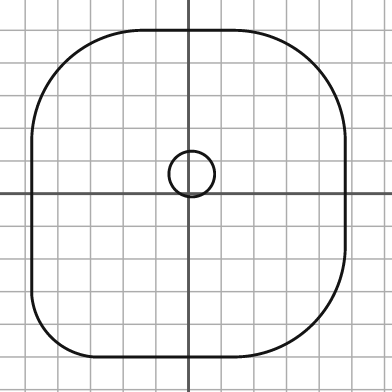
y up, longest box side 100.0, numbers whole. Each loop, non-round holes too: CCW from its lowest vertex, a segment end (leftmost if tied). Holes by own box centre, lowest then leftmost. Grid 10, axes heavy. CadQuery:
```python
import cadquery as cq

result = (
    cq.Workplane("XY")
    .moveTo(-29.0, -50.0)
    .lineTo(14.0, -50.0)
    .threePointArc((38.0, -40.0), (48.0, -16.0))
    .lineTo(48.0, 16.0)
    .threePointArc((38.0, 40.0), (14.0, 50.0))
    .lineTo(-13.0, 50.0)
    .threePointArc((-38.0, 40.0), (-48.0, 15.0))
    .lineTo(-48.0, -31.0)
    .threePointArc((-42.0, -44.0), (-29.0, -50.0))
    .close()
    .moveTo(1.0, 6.0)
    .circle(7.0)
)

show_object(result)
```